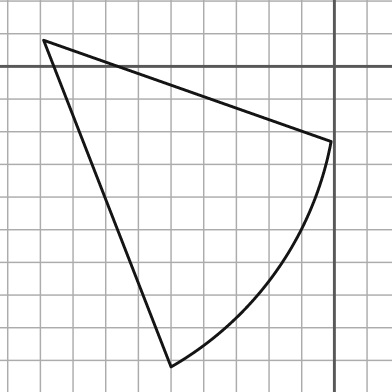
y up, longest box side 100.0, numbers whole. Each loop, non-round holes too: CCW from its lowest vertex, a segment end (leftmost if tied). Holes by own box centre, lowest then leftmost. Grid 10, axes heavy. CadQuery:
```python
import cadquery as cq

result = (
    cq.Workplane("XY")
    .moveTo(-50.0, -92.0)
    .threePointArc((-18.0, -63.0), (-1.0, -23.0))
    .lineTo(-89.0, 8.0)
    .close()
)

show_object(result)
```